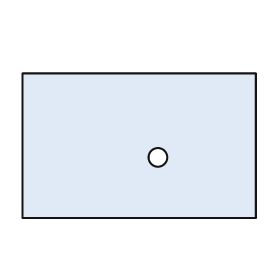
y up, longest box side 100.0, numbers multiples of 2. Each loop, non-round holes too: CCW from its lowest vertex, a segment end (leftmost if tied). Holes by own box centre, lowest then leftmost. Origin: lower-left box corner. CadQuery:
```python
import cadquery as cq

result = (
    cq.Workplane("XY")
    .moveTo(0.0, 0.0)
    .lineTo(100.0, 0.0)
    .lineTo(100.0, 62.0)
    .lineTo(0.0, 62.0)
    .close()
    .moveTo(58.0, 26.0)
    .circle(4.0)
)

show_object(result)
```